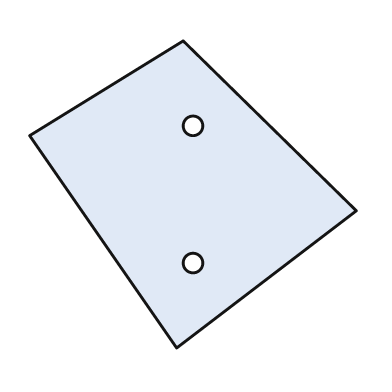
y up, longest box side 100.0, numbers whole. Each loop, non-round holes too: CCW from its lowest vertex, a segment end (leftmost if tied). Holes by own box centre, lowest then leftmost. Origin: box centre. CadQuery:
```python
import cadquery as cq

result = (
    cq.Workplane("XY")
    .moveTo(-5.0, -47.0)
    .lineTo(50.0, -5.0)
    .lineTo(-3.0, 47.0)
    .lineTo(-50.0, 18.0)
    .close()
    .moveTo(0.0, -21.0)
    .circle(3.0)
    .moveTo(0.0, 21.0)
    .circle(3.0)
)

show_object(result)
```